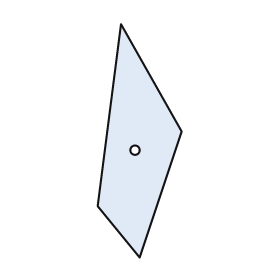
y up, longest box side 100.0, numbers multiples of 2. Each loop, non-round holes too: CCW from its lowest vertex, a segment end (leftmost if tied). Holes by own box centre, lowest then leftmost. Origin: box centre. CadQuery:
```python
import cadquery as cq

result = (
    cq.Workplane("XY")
    .moveTo(0.0, -50.0)
    .lineTo(18.0, 4.0)
    .lineTo(-8.0, 50.0)
    .lineTo(-18.0, -28.0)
    .close()
    .moveTo(-2.0, -4.0)
    .circle(2.0)
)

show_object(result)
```